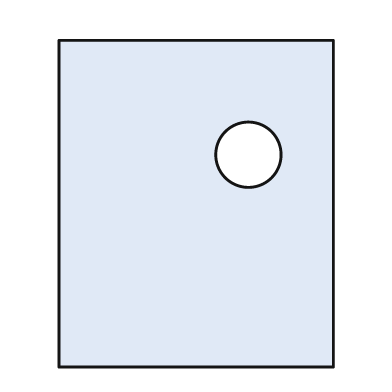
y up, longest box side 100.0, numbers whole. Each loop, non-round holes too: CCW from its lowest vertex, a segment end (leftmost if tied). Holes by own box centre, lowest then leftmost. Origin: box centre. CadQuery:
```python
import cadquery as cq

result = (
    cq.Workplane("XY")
    .moveTo(-42.0, -50.0)
    .lineTo(42.0, -50.0)
    .lineTo(42.0, 50.0)
    .lineTo(-42.0, 50.0)
    .close()
    .moveTo(16.0, 15.0)
    .circle(10.0)
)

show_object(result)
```